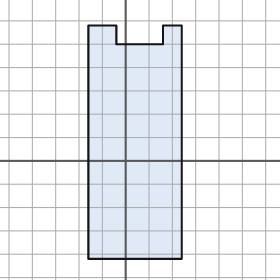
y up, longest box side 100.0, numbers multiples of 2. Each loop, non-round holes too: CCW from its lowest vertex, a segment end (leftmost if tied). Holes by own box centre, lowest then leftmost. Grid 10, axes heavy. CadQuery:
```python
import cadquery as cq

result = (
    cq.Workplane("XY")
    .moveTo(-16.0, -42.0)
    .lineTo(24.0, -42.0)
    .lineTo(24.0, 58.0)
    .lineTo(16.0, 58.0)
    .lineTo(16.0, 50.0)
    .lineTo(-4.0, 50.0)
    .lineTo(-4.0, 58.0)
    .lineTo(-16.0, 58.0)
    .close()
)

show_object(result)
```